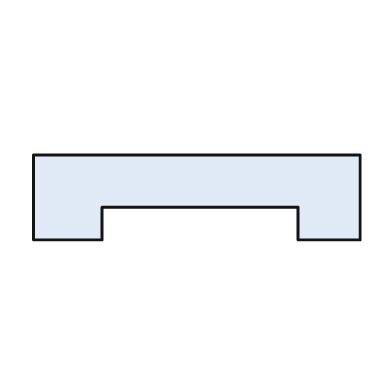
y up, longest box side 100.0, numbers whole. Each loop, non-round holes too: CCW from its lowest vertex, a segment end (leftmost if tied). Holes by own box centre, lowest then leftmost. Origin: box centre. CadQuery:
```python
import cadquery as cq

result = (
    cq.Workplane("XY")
    .moveTo(-50.0, -13.0)
    .lineTo(-29.0, -13.0)
    .lineTo(-29.0, -3.0)
    .lineTo(31.0, -3.0)
    .lineTo(31.0, -13.0)
    .lineTo(50.0, -13.0)
    .lineTo(50.0, 13.0)
    .lineTo(-50.0, 13.0)
    .close()
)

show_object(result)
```